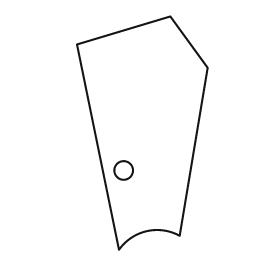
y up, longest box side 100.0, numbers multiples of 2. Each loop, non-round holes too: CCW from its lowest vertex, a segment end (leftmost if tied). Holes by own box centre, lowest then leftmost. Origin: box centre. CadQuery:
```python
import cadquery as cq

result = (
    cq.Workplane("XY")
    .moveTo(-10.0, -50.0)
    .threePointArc((2.0, -42.0), (16.0, -44.0))
    .lineTo(28.0, 28.0)
    .lineTo(12.0, 50.0)
    .lineTo(-28.0, 38.0)
    .close()
    .moveTo(-8.0, -16.0)
    .circle(4.0)
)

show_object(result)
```